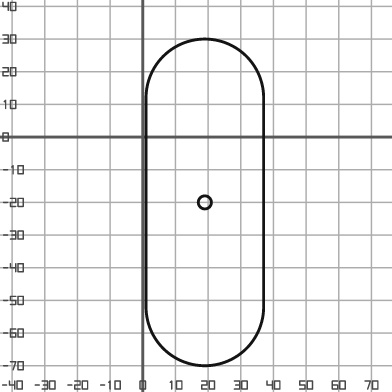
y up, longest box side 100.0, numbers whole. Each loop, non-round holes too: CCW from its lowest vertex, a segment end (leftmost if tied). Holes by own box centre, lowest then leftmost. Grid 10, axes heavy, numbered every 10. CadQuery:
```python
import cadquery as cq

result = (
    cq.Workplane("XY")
    .moveTo(1.0, -52.0)
    .threePointArc((19.0, -70.0), (37.0, -52.0))
    .lineTo(37.0, 12.0)
    .threePointArc((19.0, 30.0), (1.0, 12.0))
    .close()
    .moveTo(19.0, -20.0)
    .circle(2.0)
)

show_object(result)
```